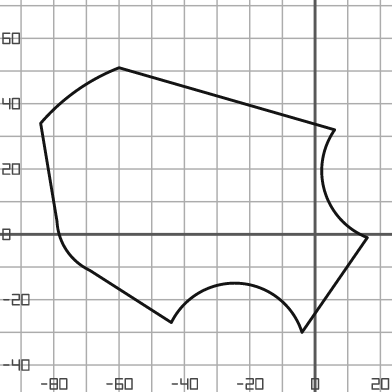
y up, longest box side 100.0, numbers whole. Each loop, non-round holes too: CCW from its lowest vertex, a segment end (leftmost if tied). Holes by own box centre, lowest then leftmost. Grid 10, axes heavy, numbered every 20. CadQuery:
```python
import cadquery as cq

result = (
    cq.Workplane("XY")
    .moveTo(-4.0, -30.0)
    .lineTo(16.0, -1.0)
    .threePointArc((3.0, 13.0), (6.0, 32.0))
    .lineTo(-60.0, 51.0)
    .threePointArc((-73.0, 44.0), (-84.0, 34.0))
    .lineTo(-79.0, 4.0)
    .threePointArc((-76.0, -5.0), (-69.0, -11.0))
    .lineTo(-44.0, -27.0)
    .threePointArc((-23.0, -15.0), (-4.0, -30.0))
    .close()
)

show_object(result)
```